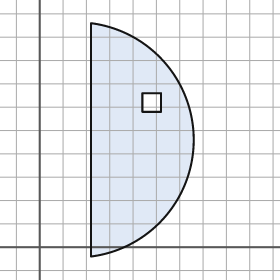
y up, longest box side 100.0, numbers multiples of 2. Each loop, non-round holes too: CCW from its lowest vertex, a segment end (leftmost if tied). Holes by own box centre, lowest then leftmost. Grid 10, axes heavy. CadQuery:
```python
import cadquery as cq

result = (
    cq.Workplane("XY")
    .moveTo(22.0, -4.0)
    .threePointArc((66.0, 46.0), (22.0, 96.0))
    .close()
    .moveTo(44.0, 58.0)
    .lineTo(52.0, 58.0)
    .lineTo(52.0, 66.0)
    .lineTo(44.0, 66.0)
    .close()
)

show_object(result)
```